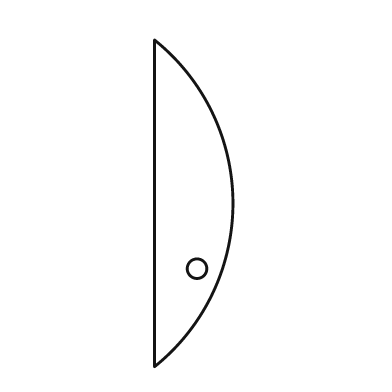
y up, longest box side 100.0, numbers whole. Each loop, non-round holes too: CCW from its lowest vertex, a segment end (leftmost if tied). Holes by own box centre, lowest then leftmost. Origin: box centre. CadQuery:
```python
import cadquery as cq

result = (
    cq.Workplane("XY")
    .moveTo(-12.0, -50.0)
    .threePointArc((12.0, 0.0), (-12.0, 50.0))
    .close()
    .moveTo(1.0, -20.0)
    .circle(3.0)
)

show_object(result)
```